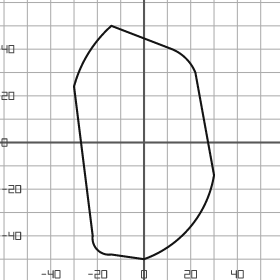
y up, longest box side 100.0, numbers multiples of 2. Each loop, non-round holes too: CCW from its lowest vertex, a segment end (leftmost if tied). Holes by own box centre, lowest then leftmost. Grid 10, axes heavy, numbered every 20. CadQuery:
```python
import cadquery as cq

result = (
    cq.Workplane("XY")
    .moveTo(0.0, -50.0)
    .threePointArc((20.0, -36.0), (30.0, -14.0))
    .lineTo(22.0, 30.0)
    .threePointArc((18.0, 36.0), (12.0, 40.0))
    .lineTo(-14.0, 50.0)
    .threePointArc((-24.0, 38.0), (-30.0, 24.0))
    .lineTo(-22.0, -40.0)
    .threePointArc((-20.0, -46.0), (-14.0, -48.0))
    .close()
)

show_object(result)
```